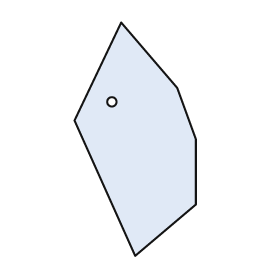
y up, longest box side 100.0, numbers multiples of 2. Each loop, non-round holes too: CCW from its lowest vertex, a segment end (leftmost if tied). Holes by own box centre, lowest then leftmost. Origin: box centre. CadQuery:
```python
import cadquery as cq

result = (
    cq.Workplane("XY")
    .moveTo(0.0, -50.0)
    .lineTo(26.0, -28.0)
    .lineTo(26.0, 0.0)
    .lineTo(18.0, 22.0)
    .lineTo(-6.0, 50.0)
    .lineTo(-26.0, 8.0)
    .close()
    .moveTo(-10.0, 16.0)
    .circle(2.0)
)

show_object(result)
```